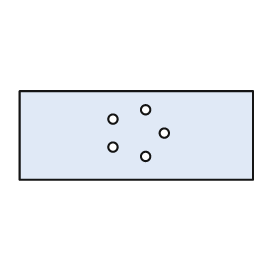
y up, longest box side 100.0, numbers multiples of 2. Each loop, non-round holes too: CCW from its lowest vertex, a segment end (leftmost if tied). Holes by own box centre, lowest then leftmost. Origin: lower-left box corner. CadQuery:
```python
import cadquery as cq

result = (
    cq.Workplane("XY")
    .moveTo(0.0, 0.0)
    .lineTo(100.0, 0.0)
    .lineTo(100.0, 38.0)
    .lineTo(0.0, 38.0)
    .close()
    .moveTo(54.0, 10.0)
    .circle(2.0)
    .moveTo(40.0, 14.0)
    .circle(2.0)
    .moveTo(62.0, 20.0)
    .circle(2.0)
    .moveTo(40.0, 26.0)
    .circle(2.0)
    .moveTo(54.0, 30.0)
    .circle(2.0)
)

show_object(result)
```